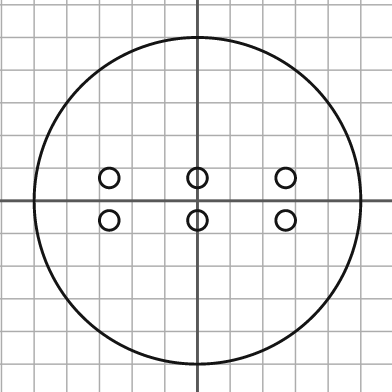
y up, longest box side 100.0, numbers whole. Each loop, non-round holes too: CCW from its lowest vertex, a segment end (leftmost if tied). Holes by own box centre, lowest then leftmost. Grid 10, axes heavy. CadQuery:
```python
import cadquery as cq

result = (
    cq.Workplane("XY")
    .moveTo(0.0, 0.0)
    .circle(50.0)
    .moveTo(-27.0, -6.0)
    .circle(3.0)
    .moveTo(0.0, -6.0)
    .circle(3.0)
    .moveTo(27.0, -6.0)
    .circle(3.0)
    .moveTo(-27.0, 7.0)
    .circle(3.0)
    .moveTo(0.0, 7.0)
    .circle(3.0)
    .moveTo(27.0, 7.0)
    .circle(3.0)
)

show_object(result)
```